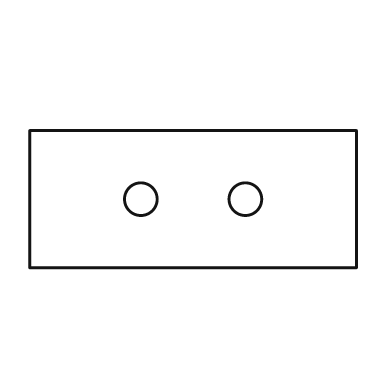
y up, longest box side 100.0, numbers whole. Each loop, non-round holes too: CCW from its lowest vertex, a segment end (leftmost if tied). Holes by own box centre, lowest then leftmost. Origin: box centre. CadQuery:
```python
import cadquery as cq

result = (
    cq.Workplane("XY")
    .moveTo(-50.0, -21.0)
    .lineTo(50.0, -21.0)
    .lineTo(50.0, 21.0)
    .lineTo(-50.0, 21.0)
    .close()
    .moveTo(-16.0, 0.0)
    .circle(5.0)
    .moveTo(16.0, 0.0)
    .circle(5.0)
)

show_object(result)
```